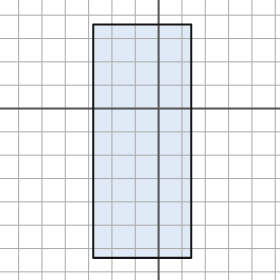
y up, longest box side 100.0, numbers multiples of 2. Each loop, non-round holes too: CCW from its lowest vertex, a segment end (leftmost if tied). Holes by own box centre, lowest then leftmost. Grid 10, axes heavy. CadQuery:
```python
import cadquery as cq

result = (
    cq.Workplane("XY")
    .moveTo(-28.0, -64.0)
    .lineTo(14.0, -64.0)
    .lineTo(14.0, 36.0)
    .lineTo(-28.0, 36.0)
    .close()
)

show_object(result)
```